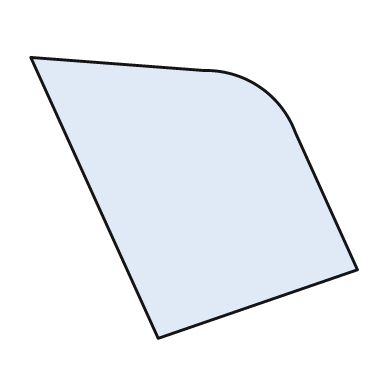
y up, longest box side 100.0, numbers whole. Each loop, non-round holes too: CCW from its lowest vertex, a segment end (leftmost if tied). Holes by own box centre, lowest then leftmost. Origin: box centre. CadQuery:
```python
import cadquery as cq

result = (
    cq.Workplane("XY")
    .moveTo(-11.0, -43.0)
    .lineTo(50.0, -22.0)
    .lineTo(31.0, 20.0)
    .threePointArc((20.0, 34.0), (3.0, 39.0))
    .lineTo(-50.0, 43.0)
    .close()
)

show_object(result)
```